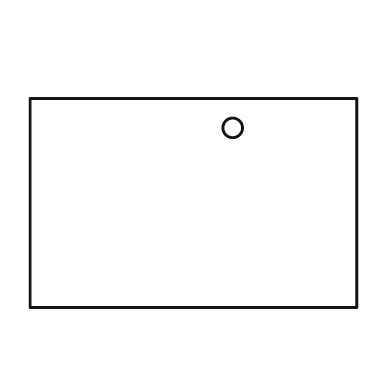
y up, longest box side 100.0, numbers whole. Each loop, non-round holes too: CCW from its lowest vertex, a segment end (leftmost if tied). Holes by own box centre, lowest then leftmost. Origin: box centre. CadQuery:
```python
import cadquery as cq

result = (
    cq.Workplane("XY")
    .moveTo(-50.0, -32.0)
    .lineTo(50.0, -32.0)
    .lineTo(50.0, 32.0)
    .lineTo(-50.0, 32.0)
    .close()
    .moveTo(12.0, 23.0)
    .circle(3.0)
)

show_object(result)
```